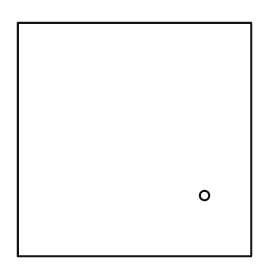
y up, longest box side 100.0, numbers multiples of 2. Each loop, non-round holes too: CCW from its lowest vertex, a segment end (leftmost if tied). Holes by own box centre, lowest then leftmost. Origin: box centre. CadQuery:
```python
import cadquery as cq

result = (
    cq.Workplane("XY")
    .moveTo(-50.0, -50.0)
    .lineTo(50.0, -50.0)
    .lineTo(50.0, 50.0)
    .lineTo(-50.0, 50.0)
    .close()
    .moveTo(30.0, -24.0)
    .circle(2.0)
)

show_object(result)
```